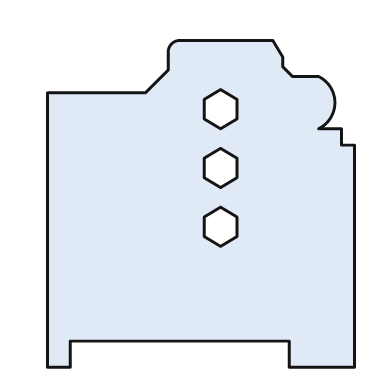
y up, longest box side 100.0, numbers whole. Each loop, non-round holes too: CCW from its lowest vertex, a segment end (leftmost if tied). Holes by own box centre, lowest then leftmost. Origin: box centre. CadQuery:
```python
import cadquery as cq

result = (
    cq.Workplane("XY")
    .moveTo(-47.0, -50.0)
    .lineTo(-40.0, -50.0)
    .lineTo(-40.0, -42.0)
    .lineTo(27.0, -42.0)
    .lineTo(27.0, -50.0)
    .lineTo(47.0, -50.0)
    .lineTo(47.0, 18.0)
    .lineTo(43.0, 18.0)
    .lineTo(43.0, 23.0)
    .lineTo(36.0, 23.0)
    .threePointArc((41.0, 31.0), (36.0, 39.0))
    .lineTo(28.0, 39.0)
    .lineTo(25.0, 42.0)
    .lineTo(25.0, 45.0)
    .lineTo(22.0, 50.0)
    .lineTo(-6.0, 50.0)
    .threePointArc((-9.0, 49.0), (-10.0, 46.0))
    .lineTo(-10.0, 41.0)
    .lineTo(-17.0, 34.0)
    .lineTo(-47.0, 34.0)
    .close()
    .moveTo(6.0, -13.0)
    .lineTo(11.0, -10.0)
    .lineTo(11.0, -4.0)
    .lineTo(6.0, -1.0)
    .lineTo(1.0, -4.0)
    .lineTo(1.0, -10.0)
    .close()
    .moveTo(6.0, 5.0)
    .lineTo(11.0, 8.0)
    .lineTo(11.0, 14.0)
    .lineTo(6.0, 17.0)
    .lineTo(1.0, 14.0)
    .lineTo(1.0, 8.0)
    .close()
    .moveTo(6.0, 23.0)
    .lineTo(11.0, 26.0)
    .lineTo(11.0, 32.0)
    .lineTo(6.0, 35.0)
    .lineTo(1.0, 32.0)
    .lineTo(1.0, 26.0)
    .close()
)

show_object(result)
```